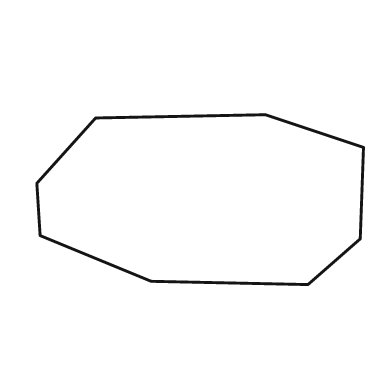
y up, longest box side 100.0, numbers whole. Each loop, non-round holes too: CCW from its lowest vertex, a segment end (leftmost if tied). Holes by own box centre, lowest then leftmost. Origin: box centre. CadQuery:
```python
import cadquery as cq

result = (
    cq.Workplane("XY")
    .moveTo(33.0, -26.0)
    .lineTo(49.0, -12.0)
    .lineTo(50.0, 16.0)
    .lineTo(20.0, 26.0)
    .lineTo(-32.0, 25.0)
    .lineTo(-50.0, 5.0)
    .lineTo(-49.0, -11.0)
    .lineTo(-15.0, -25.0)
    .close()
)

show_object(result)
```